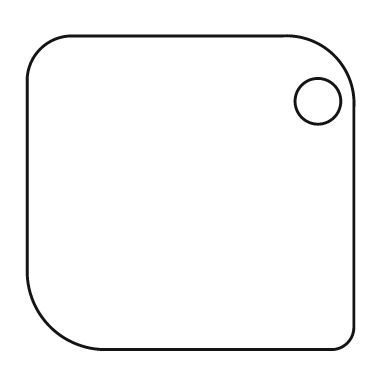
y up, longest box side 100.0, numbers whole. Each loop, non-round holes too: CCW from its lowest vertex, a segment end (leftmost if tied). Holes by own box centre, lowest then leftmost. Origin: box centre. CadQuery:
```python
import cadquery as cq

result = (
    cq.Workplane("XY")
    .moveTo(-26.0, -48.0)
    .lineTo(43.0, -48.0)
    .threePointArc((48.0, -46.0), (50.0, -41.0))
    .lineTo(50.0, 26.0)
    .threePointArc((44.0, 42.0), (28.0, 48.0))
    .lineTo(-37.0, 48.0)
    .threePointArc((-46.0, 44.0), (-50.0, 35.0))
    .lineTo(-50.0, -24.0)
    .threePointArc((-43.0, -41.0), (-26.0, -48.0))
    .close()
    .moveTo(39.0, 28.0)
    .circle(7.0)
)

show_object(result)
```